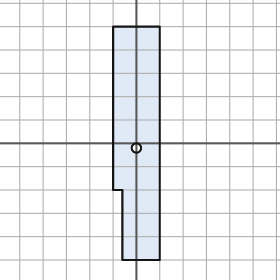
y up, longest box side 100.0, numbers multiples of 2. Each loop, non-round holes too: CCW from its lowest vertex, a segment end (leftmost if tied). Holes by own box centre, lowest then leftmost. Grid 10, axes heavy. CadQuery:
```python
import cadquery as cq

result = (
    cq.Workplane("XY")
    .moveTo(-6.0, -50.0)
    .lineTo(10.0, -50.0)
    .lineTo(10.0, 50.0)
    .lineTo(-10.0, 50.0)
    .lineTo(-10.0, -20.0)
    .lineTo(-6.0, -20.0)
    .close()
    .moveTo(0.0, -2.0)
    .circle(2.0)
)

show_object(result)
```